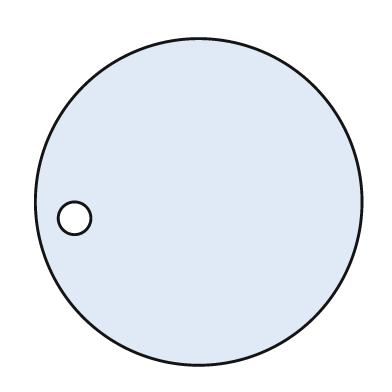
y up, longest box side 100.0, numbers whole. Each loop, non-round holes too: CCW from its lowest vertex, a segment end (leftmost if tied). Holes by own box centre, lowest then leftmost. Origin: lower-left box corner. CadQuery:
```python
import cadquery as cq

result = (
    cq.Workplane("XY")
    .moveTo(50.0, 50.0)
    .circle(50.0)
    .moveTo(12.0, 45.0)
    .circle(5.0)
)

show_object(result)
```